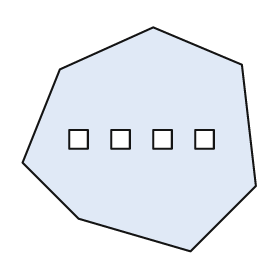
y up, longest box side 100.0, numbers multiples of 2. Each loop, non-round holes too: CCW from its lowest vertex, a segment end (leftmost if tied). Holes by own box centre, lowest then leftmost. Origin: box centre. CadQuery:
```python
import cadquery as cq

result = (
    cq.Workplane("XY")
    .moveTo(22.0, -48.0)
    .lineTo(50.0, -20.0)
    .lineTo(44.0, 32.0)
    .lineTo(6.0, 48.0)
    .lineTo(-34.0, 30.0)
    .lineTo(-50.0, -10.0)
    .lineTo(-26.0, -34.0)
    .close()
    .moveTo(-30.0, -4.0)
    .lineTo(-22.0, -4.0)
    .lineTo(-22.0, 4.0)
    .lineTo(-30.0, 4.0)
    .close()
    .moveTo(-12.0, -4.0)
    .lineTo(-4.0, -4.0)
    .lineTo(-4.0, 4.0)
    .lineTo(-12.0, 4.0)
    .close()
    .moveTo(6.0, -4.0)
    .lineTo(14.0, -4.0)
    .lineTo(14.0, 4.0)
    .lineTo(6.0, 4.0)
    .close()
    .moveTo(24.0, -4.0)
    .lineTo(32.0, -4.0)
    .lineTo(32.0, 4.0)
    .lineTo(24.0, 4.0)
    .close()
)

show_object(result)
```